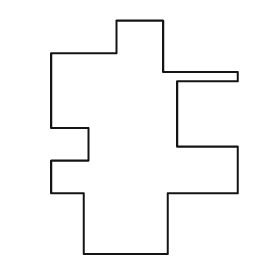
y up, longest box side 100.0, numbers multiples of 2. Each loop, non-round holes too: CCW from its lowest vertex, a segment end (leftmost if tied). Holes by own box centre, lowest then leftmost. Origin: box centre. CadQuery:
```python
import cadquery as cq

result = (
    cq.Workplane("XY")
    .moveTo(-26.0, -50.0)
    .lineTo(10.0, -50.0)
    .lineTo(10.0, -24.0)
    .lineTo(40.0, -24.0)
    .lineTo(40.0, -4.0)
    .lineTo(14.0, -4.0)
    .lineTo(14.0, 24.0)
    .lineTo(40.0, 24.0)
    .lineTo(40.0, 28.0)
    .lineTo(8.0, 28.0)
    .lineTo(8.0, 50.0)
    .lineTo(-12.0, 50.0)
    .lineTo(-12.0, 36.0)
    .lineTo(-40.0, 36.0)
    .lineTo(-40.0, 4.0)
    .lineTo(-24.0, 4.0)
    .lineTo(-24.0, -10.0)
    .lineTo(-40.0, -10.0)
    .lineTo(-40.0, -24.0)
    .lineTo(-26.0, -24.0)
    .close()
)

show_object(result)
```